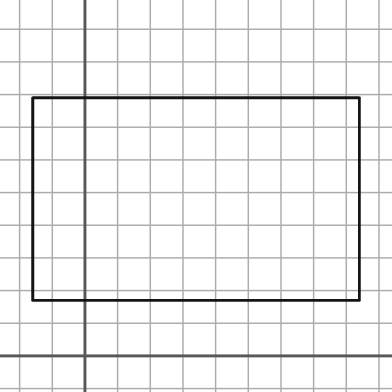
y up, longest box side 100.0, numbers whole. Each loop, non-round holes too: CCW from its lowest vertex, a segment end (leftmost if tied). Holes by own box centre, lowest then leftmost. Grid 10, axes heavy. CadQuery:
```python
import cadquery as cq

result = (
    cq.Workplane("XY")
    .moveTo(-16.0, 17.0)
    .lineTo(84.0, 17.0)
    .lineTo(84.0, 79.0)
    .lineTo(-16.0, 79.0)
    .close()
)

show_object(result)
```